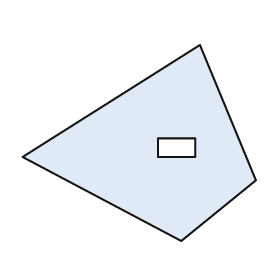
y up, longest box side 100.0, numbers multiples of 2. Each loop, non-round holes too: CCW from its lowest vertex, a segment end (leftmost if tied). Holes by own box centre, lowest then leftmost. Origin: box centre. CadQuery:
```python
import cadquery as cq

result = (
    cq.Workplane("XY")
    .moveTo(18.0, -42.0)
    .lineTo(50.0, -16.0)
    .lineTo(26.0, 42.0)
    .lineTo(-50.0, -6.0)
    .close()
    .moveTo(8.0, -6.0)
    .lineTo(24.0, -6.0)
    .lineTo(24.0, 2.0)
    .lineTo(8.0, 2.0)
    .close()
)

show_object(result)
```